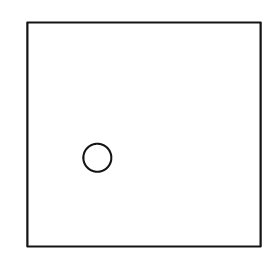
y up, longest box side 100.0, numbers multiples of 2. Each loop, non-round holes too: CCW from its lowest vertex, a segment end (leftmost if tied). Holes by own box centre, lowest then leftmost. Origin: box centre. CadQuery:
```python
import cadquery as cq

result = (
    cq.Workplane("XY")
    .moveTo(-50.0, -48.0)
    .lineTo(50.0, -48.0)
    .lineTo(50.0, 48.0)
    .lineTo(-50.0, 48.0)
    .close()
    .moveTo(-20.0, -10.0)
    .circle(6.0)
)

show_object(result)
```